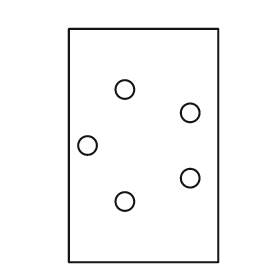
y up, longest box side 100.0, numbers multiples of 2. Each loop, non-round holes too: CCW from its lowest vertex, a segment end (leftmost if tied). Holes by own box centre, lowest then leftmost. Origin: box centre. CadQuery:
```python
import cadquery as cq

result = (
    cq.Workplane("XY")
    .moveTo(-32.0, -50.0)
    .lineTo(32.0, -50.0)
    .lineTo(32.0, 50.0)
    .lineTo(-32.0, 50.0)
    .close()
    .moveTo(-8.0, -24.0)
    .circle(4.0)
    .moveTo(20.0, -14.0)
    .circle(4.0)
    .moveTo(-24.0, 0.0)
    .circle(4.0)
    .moveTo(20.0, 14.0)
    .circle(4.0)
    .moveTo(-8.0, 24.0)
    .circle(4.0)
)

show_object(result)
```